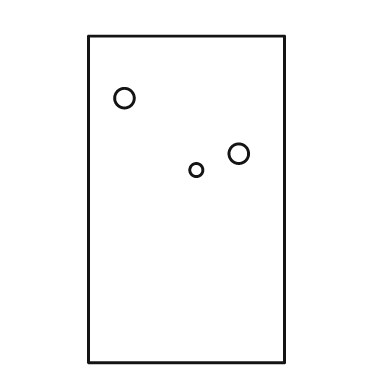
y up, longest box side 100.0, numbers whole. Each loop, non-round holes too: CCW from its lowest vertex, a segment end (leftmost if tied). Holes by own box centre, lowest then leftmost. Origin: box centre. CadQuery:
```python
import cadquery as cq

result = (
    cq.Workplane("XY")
    .moveTo(-30.0, -50.0)
    .lineTo(30.0, -50.0)
    .lineTo(30.0, 50.0)
    .lineTo(-30.0, 50.0)
    .close()
    .moveTo(3.0, 9.0)
    .circle(2.0)
    .moveTo(16.0, 14.0)
    .circle(3.0)
    .moveTo(-19.0, 31.0)
    .circle(3.0)
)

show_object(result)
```